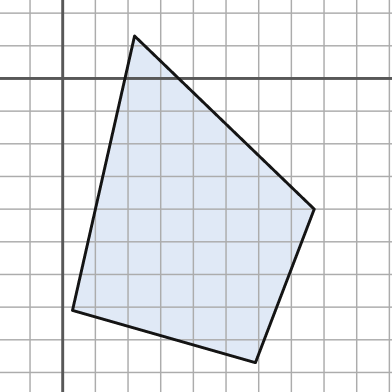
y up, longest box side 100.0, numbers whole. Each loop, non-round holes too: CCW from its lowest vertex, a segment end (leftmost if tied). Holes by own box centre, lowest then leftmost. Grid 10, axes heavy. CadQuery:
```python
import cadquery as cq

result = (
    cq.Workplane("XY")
    .moveTo(59.0, -87.0)
    .lineTo(77.0, -40.0)
    .lineTo(22.0, 13.0)
    .lineTo(3.0, -71.0)
    .close()
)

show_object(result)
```